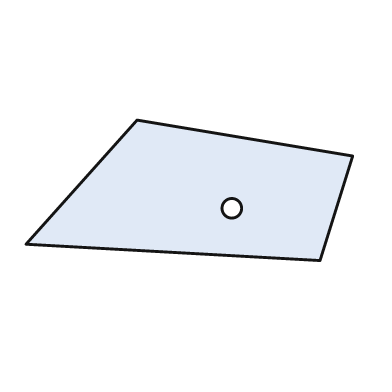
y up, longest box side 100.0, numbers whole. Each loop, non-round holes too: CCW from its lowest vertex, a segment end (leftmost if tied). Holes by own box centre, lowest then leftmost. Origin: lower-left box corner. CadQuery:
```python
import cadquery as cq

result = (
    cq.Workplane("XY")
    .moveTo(90.0, 0.0)
    .lineTo(100.0, 32.0)
    .lineTo(34.0, 43.0)
    .lineTo(0.0, 5.0)
    .close()
    .moveTo(63.0, 16.0)
    .circle(3.0)
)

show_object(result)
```